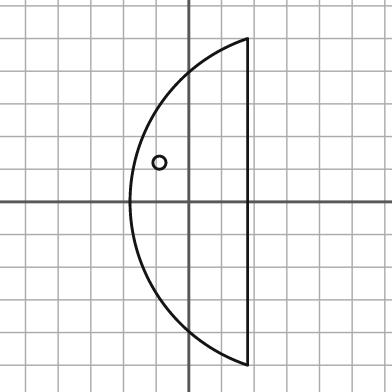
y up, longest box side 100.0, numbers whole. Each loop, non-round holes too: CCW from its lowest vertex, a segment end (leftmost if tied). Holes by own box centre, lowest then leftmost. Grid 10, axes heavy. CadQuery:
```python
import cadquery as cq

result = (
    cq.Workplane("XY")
    .moveTo(18.0, -50.0)
    .lineTo(18.0, 50.0)
    .threePointArc((-18.0, 0.0), (18.0, -50.0))
    .close()
    .moveTo(-9.0, 12.0)
    .circle(2.0)
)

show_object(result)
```